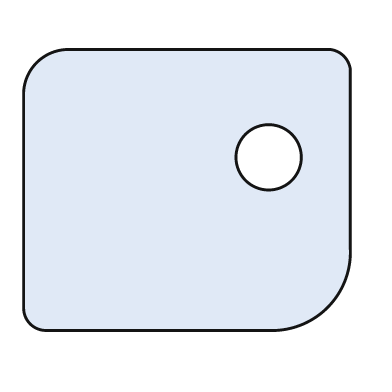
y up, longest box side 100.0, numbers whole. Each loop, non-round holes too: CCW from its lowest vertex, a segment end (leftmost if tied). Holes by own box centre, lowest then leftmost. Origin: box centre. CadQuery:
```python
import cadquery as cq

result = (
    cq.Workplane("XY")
    .moveTo(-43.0, -43.0)
    .lineTo(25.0, -43.0)
    .threePointArc((43.0, -36.0), (50.0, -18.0))
    .lineTo(50.0, 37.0)
    .threePointArc((48.0, 41.0), (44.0, 43.0))
    .lineTo(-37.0, 43.0)
    .threePointArc((-46.0, 39.0), (-50.0, 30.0))
    .lineTo(-50.0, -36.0)
    .threePointArc((-48.0, -41.0), (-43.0, -43.0))
    .close()
    .moveTo(25.0, 10.0)
    .circle(10.0)
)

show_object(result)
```